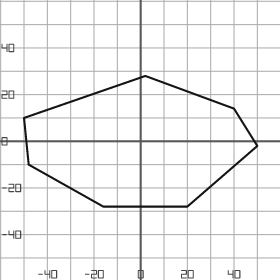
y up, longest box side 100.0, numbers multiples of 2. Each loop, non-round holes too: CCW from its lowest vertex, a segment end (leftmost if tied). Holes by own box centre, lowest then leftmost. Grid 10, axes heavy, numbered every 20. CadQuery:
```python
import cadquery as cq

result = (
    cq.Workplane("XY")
    .moveTo(-16.0, -28.0)
    .lineTo(20.0, -28.0)
    .lineTo(50.0, -2.0)
    .lineTo(40.0, 14.0)
    .lineTo(2.0, 28.0)
    .lineTo(-50.0, 10.0)
    .lineTo(-48.0, -10.0)
    .close()
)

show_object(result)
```